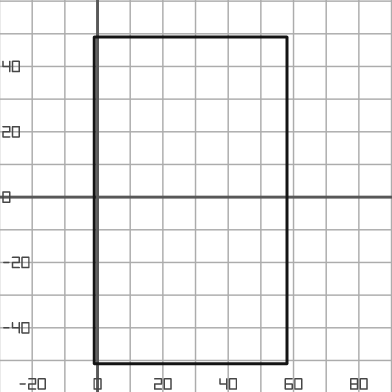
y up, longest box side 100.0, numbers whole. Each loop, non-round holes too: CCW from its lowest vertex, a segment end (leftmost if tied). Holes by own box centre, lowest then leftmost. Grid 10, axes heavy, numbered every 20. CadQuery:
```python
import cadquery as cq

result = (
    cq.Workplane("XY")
    .moveTo(-1.0, -51.0)
    .lineTo(58.0, -51.0)
    .lineTo(58.0, 49.0)
    .lineTo(-1.0, 49.0)
    .close()
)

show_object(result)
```